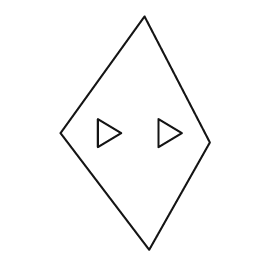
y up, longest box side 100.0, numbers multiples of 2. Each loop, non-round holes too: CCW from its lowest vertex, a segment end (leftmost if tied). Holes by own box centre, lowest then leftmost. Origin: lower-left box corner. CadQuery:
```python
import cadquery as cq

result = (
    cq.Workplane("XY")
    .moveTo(38.0, 0.0)
    .lineTo(64.0, 46.0)
    .lineTo(36.0, 100.0)
    .lineTo(0.0, 50.0)
    .close()
    .moveTo(16.0, 44.0)
    .lineTo(26.0, 50.0)
    .lineTo(16.0, 56.0)
    .close()
    .moveTo(42.0, 44.0)
    .lineTo(52.0, 50.0)
    .lineTo(42.0, 56.0)
    .close()
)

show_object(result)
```